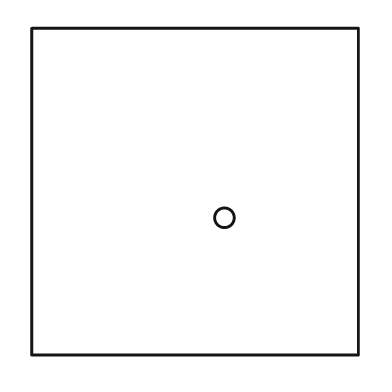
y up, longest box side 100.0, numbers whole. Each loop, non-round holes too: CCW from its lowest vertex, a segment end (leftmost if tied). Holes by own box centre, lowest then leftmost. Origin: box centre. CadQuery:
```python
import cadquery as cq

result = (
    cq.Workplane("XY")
    .moveTo(-50.0, -50.0)
    .lineTo(50.0, -50.0)
    .lineTo(50.0, 50.0)
    .lineTo(-50.0, 50.0)
    .close()
    .moveTo(9.0, -8.0)
    .circle(3.0)
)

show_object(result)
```